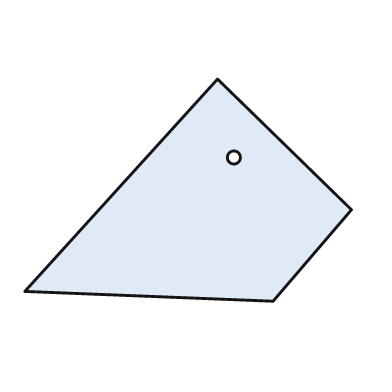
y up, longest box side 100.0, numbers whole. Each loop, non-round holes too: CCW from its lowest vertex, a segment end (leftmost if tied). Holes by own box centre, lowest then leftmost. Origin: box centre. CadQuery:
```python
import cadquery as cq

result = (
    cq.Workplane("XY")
    .moveTo(26.0, -34.0)
    .lineTo(50.0, -6.0)
    .lineTo(9.0, 34.0)
    .lineTo(-50.0, -31.0)
    .close()
    .moveTo(14.0, 10.0)
    .circle(2.0)
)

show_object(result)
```